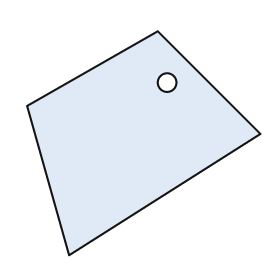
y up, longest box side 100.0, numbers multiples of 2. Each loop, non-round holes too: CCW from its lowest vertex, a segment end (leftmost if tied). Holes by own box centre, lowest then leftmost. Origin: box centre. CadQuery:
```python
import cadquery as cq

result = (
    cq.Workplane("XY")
    .moveTo(-32.0, -48.0)
    .lineTo(50.0, 4.0)
    .lineTo(6.0, 48.0)
    .lineTo(-50.0, 16.0)
    .close()
    .moveTo(10.0, 26.0)
    .circle(4.0)
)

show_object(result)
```